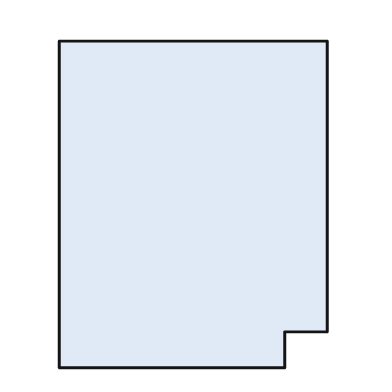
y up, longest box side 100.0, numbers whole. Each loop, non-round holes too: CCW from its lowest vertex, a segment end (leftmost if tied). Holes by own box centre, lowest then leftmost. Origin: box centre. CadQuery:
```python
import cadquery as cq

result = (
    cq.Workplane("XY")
    .moveTo(-41.0, -50.0)
    .lineTo(28.0, -50.0)
    .lineTo(28.0, -39.0)
    .lineTo(41.0, -39.0)
    .lineTo(41.0, 50.0)
    .lineTo(-41.0, 50.0)
    .close()
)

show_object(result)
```